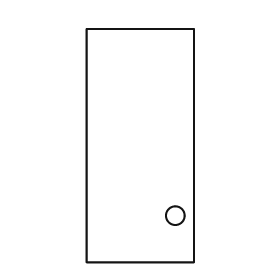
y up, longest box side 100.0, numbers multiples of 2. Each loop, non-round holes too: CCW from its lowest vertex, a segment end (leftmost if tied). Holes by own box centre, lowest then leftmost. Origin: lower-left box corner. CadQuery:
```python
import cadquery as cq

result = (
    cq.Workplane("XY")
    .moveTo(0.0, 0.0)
    .lineTo(46.0, 0.0)
    .lineTo(46.0, 100.0)
    .lineTo(0.0, 100.0)
    .close()
    .moveTo(38.0, 20.0)
    .circle(4.0)
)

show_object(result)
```